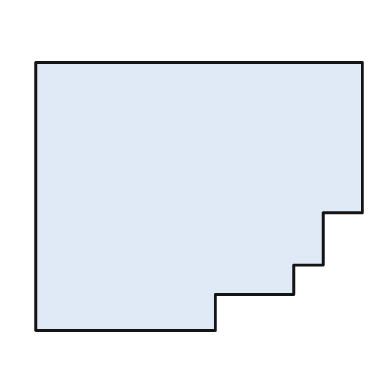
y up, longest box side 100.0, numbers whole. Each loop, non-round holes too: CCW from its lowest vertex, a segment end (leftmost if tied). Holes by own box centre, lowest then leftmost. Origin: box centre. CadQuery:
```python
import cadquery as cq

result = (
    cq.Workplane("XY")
    .moveTo(-50.0, -41.0)
    .lineTo(5.0, -41.0)
    .lineTo(5.0, -30.0)
    .lineTo(29.0, -30.0)
    .lineTo(29.0, -21.0)
    .lineTo(38.0, -21.0)
    .lineTo(38.0, -5.0)
    .lineTo(50.0, -5.0)
    .lineTo(50.0, 41.0)
    .lineTo(-50.0, 41.0)
    .close()
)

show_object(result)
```